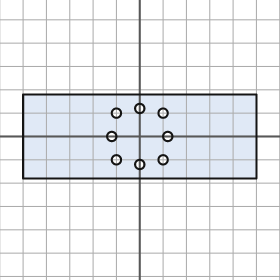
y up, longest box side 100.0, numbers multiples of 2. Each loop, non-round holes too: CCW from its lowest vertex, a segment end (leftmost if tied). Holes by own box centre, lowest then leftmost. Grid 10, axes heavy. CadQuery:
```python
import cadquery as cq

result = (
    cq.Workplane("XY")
    .moveTo(-50.0, -18.0)
    .lineTo(50.0, -18.0)
    .lineTo(50.0, 18.0)
    .lineTo(-50.0, 18.0)
    .close()
    .moveTo(0.0, -12.0)
    .circle(2.0)
    .moveTo(-10.0, -10.0)
    .circle(2.0)
    .moveTo(10.0, -10.0)
    .circle(2.0)
    .moveTo(-12.0, 0.0)
    .circle(2.0)
    .moveTo(12.0, 0.0)
    .circle(2.0)
    .moveTo(-10.0, 10.0)
    .circle(2.0)
    .moveTo(10.0, 10.0)
    .circle(2.0)
    .moveTo(0.0, 12.0)
    .circle(2.0)
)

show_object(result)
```